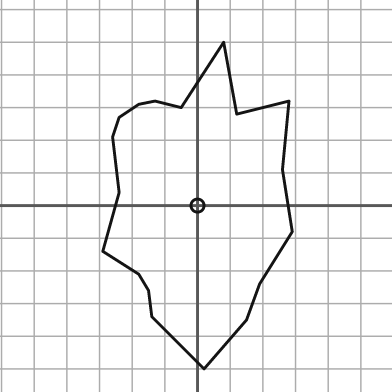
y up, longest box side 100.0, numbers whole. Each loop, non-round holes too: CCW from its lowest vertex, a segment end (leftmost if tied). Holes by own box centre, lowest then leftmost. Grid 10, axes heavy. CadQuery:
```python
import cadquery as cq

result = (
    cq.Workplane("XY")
    .moveTo(2.0, -50.0)
    .lineTo(15.0, -35.0)
    .lineTo(19.0, -24.0)
    .lineTo(29.0, -8.0)
    .lineTo(26.0, 11.0)
    .lineTo(28.0, 32.0)
    .lineTo(12.0, 28.0)
    .lineTo(8.0, 50.0)
    .lineTo(-5.0, 30.0)
    .lineTo(-13.0, 32.0)
    .lineTo(-18.0, 31.0)
    .lineTo(-24.0, 27.0)
    .lineTo(-26.0, 21.0)
    .lineTo(-24.0, 4.0)
    .lineTo(-29.0, -14.0)
    .lineTo(-18.0, -21.0)
    .lineTo(-15.0, -26.0)
    .lineTo(-14.0, -34.0)
    .close()
    .moveTo(0.0, 0.0)
    .circle(2.0)
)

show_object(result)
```